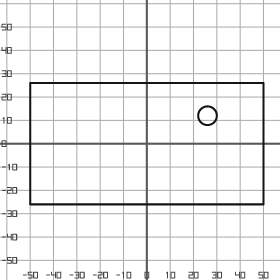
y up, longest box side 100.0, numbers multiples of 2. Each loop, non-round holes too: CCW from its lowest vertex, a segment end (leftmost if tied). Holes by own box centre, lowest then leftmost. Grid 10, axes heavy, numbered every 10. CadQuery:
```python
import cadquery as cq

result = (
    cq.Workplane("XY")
    .moveTo(-50.0, -26.0)
    .lineTo(50.0, -26.0)
    .lineTo(50.0, 26.0)
    .lineTo(-50.0, 26.0)
    .close()
    .moveTo(26.0, 12.0)
    .circle(4.0)
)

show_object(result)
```